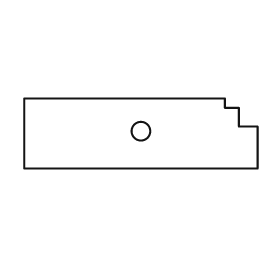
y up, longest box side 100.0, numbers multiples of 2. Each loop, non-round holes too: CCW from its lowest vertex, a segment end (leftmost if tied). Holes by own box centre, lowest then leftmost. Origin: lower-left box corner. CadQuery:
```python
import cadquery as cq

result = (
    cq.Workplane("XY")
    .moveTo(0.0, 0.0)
    .lineTo(100.0, 0.0)
    .lineTo(100.0, 18.0)
    .lineTo(92.0, 18.0)
    .lineTo(92.0, 26.0)
    .lineTo(86.0, 26.0)
    .lineTo(86.0, 30.0)
    .lineTo(0.0, 30.0)
    .close()
    .moveTo(50.0, 16.0)
    .circle(4.0)
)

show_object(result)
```